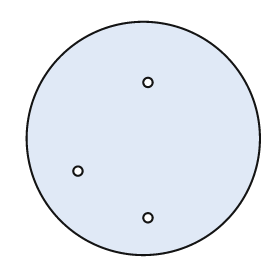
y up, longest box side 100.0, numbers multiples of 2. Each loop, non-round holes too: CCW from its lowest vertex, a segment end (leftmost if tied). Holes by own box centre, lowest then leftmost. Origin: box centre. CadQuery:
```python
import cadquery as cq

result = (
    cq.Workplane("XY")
    .moveTo(0.0, 0.0)
    .circle(50.0)
    .moveTo(2.0, -34.0)
    .circle(2.0)
    .moveTo(-28.0, -14.0)
    .circle(2.0)
    .moveTo(2.0, 24.0)
    .circle(2.0)
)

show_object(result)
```